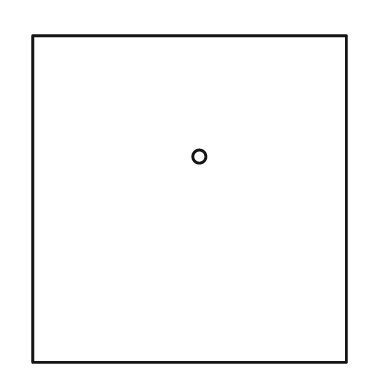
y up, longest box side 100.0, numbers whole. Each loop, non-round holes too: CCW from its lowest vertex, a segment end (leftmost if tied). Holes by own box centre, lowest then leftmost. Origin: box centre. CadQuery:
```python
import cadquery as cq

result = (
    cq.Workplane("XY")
    .moveTo(-48.0, -50.0)
    .lineTo(48.0, -50.0)
    .lineTo(48.0, 50.0)
    .lineTo(-48.0, 50.0)
    .close()
    .moveTo(3.0, 13.0)
    .circle(2.0)
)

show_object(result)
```